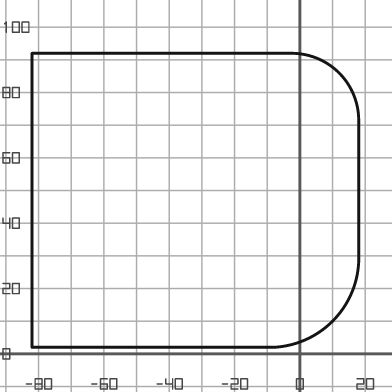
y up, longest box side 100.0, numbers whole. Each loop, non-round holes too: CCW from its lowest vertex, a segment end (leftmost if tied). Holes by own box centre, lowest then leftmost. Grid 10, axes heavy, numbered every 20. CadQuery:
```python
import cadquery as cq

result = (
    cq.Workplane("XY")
    .moveTo(-82.0, 2.0)
    .lineTo(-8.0, 2.0)
    .threePointArc((10.0, 10.0), (18.0, 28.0))
    .lineTo(18.0, 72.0)
    .threePointArc((12.0, 86.0), (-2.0, 92.0))
    .lineTo(-82.0, 92.0)
    .close()
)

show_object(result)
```